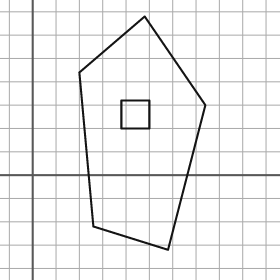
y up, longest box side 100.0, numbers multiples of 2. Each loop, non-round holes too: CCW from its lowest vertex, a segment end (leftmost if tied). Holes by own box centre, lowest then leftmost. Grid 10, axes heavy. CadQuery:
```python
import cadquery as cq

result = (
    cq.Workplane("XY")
    .moveTo(58.0, -32.0)
    .lineTo(74.0, 30.0)
    .lineTo(48.0, 68.0)
    .lineTo(20.0, 44.0)
    .lineTo(26.0, -22.0)
    .close()
    .moveTo(38.0, 20.0)
    .lineTo(50.0, 20.0)
    .lineTo(50.0, 32.0)
    .lineTo(38.0, 32.0)
    .close()
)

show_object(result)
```